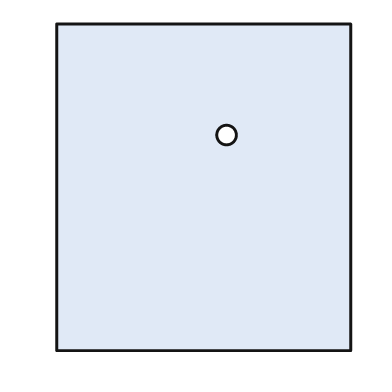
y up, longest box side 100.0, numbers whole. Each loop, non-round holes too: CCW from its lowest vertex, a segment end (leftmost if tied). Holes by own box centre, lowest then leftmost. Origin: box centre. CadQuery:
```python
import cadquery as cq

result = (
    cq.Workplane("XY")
    .moveTo(-45.0, -50.0)
    .lineTo(45.0, -50.0)
    .lineTo(45.0, 50.0)
    .lineTo(-45.0, 50.0)
    .close()
    .moveTo(7.0, 16.0)
    .circle(3.0)
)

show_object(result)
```